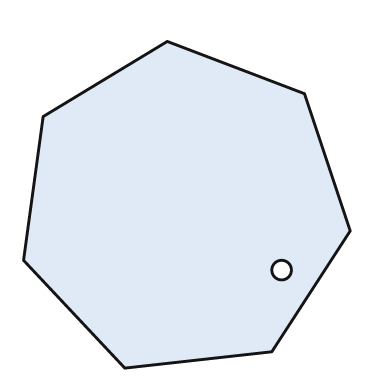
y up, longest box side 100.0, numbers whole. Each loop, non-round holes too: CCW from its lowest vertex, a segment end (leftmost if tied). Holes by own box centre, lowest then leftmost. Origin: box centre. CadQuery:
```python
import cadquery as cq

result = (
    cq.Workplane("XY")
    .moveTo(-19.0, -50.0)
    .lineTo(26.0, -45.0)
    .lineTo(50.0, -8.0)
    .lineTo(36.0, 34.0)
    .lineTo(-6.0, 50.0)
    .lineTo(-44.0, 27.0)
    .lineTo(-50.0, -17.0)
    .close()
    .moveTo(29.0, -20.0)
    .circle(3.0)
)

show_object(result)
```